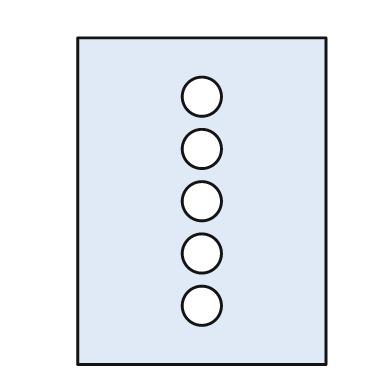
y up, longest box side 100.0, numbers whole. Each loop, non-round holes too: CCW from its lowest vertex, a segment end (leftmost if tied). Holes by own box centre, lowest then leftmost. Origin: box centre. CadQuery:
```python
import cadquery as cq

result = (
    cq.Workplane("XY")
    .moveTo(-38.0, -50.0)
    .lineTo(38.0, -50.0)
    .lineTo(38.0, 50.0)
    .lineTo(-38.0, 50.0)
    .close()
    .moveTo(0.0, -32.0)
    .circle(6.0)
    .moveTo(0.0, -16.0)
    .circle(6.0)
    .moveTo(0.0, 0.0)
    .circle(6.0)
    .moveTo(0.0, 16.0)
    .circle(6.0)
    .moveTo(0.0, 32.0)
    .circle(6.0)
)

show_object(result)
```